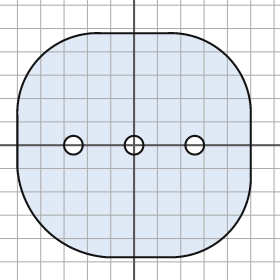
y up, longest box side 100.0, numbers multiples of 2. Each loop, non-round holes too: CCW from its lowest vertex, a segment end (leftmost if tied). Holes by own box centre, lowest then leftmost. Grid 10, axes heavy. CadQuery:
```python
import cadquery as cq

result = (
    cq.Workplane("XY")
    .moveTo(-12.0, -48.0)
    .lineTo(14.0, -48.0)
    .threePointArc((40.0, -38.0), (50.0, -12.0))
    .lineTo(50.0, 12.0)
    .threePointArc((40.0, 38.0), (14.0, 48.0))
    .lineTo(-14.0, 48.0)
    .threePointArc((-40.0, 38.0), (-50.0, 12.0))
    .lineTo(-50.0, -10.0)
    .threePointArc((-38.0, -36.0), (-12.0, -48.0))
    .close()
    .moveTo(-26.0, 0.0)
    .circle(4.0)
    .moveTo(0.0, 0.0)
    .circle(4.0)
    .moveTo(26.0, 0.0)
    .circle(4.0)
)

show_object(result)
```